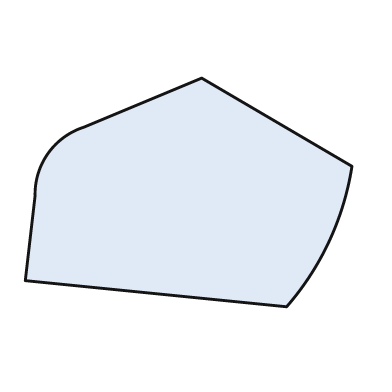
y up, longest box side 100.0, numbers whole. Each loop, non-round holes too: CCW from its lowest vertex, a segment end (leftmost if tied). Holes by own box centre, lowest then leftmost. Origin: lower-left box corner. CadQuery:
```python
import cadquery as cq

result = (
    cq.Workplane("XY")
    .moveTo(80.0, 0.0)
    .threePointArc((93.0, 20.0), (100.0, 43.0))
    .lineTo(54.0, 70.0)
    .lineTo(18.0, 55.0)
    .threePointArc((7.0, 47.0), (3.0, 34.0))
    .lineTo(0.0, 8.0)
    .close()
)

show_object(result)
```